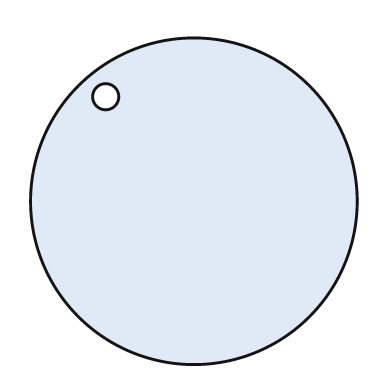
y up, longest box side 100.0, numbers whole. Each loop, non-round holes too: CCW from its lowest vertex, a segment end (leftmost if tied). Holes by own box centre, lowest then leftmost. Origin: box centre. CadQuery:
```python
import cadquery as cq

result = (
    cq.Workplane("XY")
    .moveTo(0.0, 0.0)
    .circle(50.0)
    .moveTo(-27.0, 32.0)
    .circle(4.0)
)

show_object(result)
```